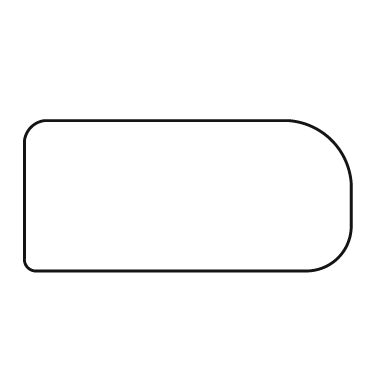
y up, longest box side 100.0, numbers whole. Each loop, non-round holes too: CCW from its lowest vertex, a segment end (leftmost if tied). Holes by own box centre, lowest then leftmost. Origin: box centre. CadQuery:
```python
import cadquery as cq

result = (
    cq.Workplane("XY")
    .moveTo(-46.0, -23.0)
    .lineTo(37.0, -23.0)
    .threePointArc((46.0, -19.0), (50.0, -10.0))
    .lineTo(50.0, 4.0)
    .threePointArc((44.0, 17.0), (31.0, 23.0))
    .lineTo(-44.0, 23.0)
    .threePointArc((-48.0, 21.0), (-50.0, 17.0))
    .lineTo(-50.0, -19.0)
    .threePointArc((-49.0, -22.0), (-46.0, -23.0))
    .close()
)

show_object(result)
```